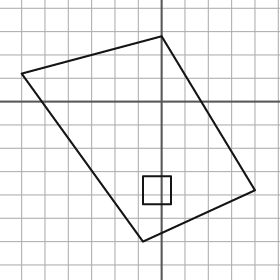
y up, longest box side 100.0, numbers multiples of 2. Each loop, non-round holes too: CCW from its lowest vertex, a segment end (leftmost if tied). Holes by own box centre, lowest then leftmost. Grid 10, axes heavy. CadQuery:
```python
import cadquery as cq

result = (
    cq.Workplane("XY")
    .moveTo(-8.0, -60.0)
    .lineTo(40.0, -38.0)
    .lineTo(0.0, 28.0)
    .lineTo(-60.0, 12.0)
    .close()
    .moveTo(-8.0, -44.0)
    .lineTo(4.0, -44.0)
    .lineTo(4.0, -32.0)
    .lineTo(-8.0, -32.0)
    .close()
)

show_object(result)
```